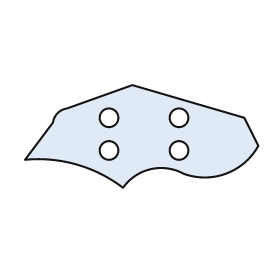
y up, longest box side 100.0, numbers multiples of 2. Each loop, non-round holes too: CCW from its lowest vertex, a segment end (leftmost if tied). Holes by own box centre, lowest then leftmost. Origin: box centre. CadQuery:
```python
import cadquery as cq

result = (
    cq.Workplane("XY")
    .moveTo(-8.0, -22.0)
    .threePointArc((4.0, -14.0), (18.0, -16.0))
    .threePointArc((36.0, -16.0), (50.0, -4.0))
    .lineTo(44.0, 8.0)
    .lineTo(-4.0, 22.0)
    .lineTo(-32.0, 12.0)
    .threePointArc((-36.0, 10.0), (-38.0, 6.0))
    .lineTo(-50.0, -10.0)
    .threePointArc((-28.0, -12.0), (-8.0, -22.0))
    .close()
    .moveTo(-14.0, -6.0)
    .circle(4.0)
    .moveTo(16.0, -6.0)
    .circle(4.0)
    .moveTo(-14.0, 8.0)
    .circle(4.0)
    .moveTo(16.0, 8.0)
    .circle(4.0)
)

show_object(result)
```